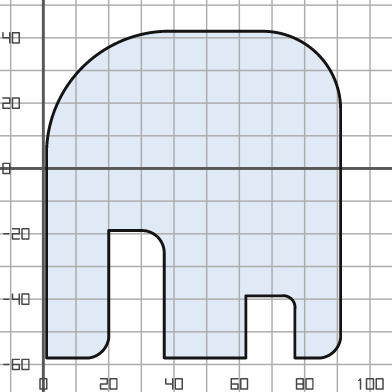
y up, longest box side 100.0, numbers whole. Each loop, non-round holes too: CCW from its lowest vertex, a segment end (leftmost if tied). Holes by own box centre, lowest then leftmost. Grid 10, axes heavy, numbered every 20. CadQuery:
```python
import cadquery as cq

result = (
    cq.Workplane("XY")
    .moveTo(1.0, -58.0)
    .lineTo(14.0, -58.0)
    .threePointArc((18.0, -56.0), (20.0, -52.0))
    .lineTo(20.0, -19.0)
    .lineTo(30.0, -19.0)
    .threePointArc((35.0, -21.0), (37.0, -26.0))
    .lineTo(37.0, -58.0)
    .lineTo(62.0, -58.0)
    .lineTo(62.0, -39.0)
    .lineTo(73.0, -39.0)
    .threePointArc((76.0, -40.0), (77.0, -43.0))
    .lineTo(77.0, -58.0)
    .lineTo(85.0, -58.0)
    .threePointArc((89.0, -56.0), (91.0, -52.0))
    .lineTo(91.0, 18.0)
    .threePointArc((84.0, 35.0), (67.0, 42.0))
    .lineTo(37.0, 42.0)
    .threePointArc((12.0, 31.0), (1.0, 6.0))
    .close()
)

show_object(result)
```